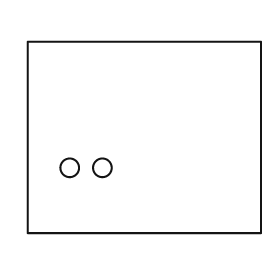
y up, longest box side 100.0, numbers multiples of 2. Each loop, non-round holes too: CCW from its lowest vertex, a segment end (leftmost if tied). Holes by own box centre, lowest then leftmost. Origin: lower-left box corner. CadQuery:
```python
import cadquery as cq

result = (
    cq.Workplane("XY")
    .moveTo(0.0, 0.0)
    .lineTo(100.0, 0.0)
    .lineTo(100.0, 82.0)
    .lineTo(0.0, 82.0)
    .close()
    .moveTo(18.0, 28.0)
    .circle(4.0)
    .moveTo(32.0, 28.0)
    .circle(4.0)
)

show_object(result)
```